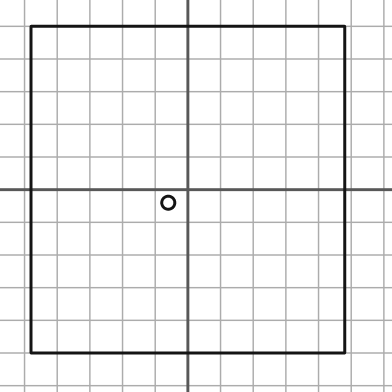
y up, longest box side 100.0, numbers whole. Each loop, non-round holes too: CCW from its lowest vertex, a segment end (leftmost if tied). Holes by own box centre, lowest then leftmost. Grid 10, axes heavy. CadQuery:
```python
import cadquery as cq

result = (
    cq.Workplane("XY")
    .moveTo(-48.0, -50.0)
    .lineTo(48.0, -50.0)
    .lineTo(48.0, 50.0)
    .lineTo(-48.0, 50.0)
    .close()
    .moveTo(-6.0, -4.0)
    .circle(2.0)
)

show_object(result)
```